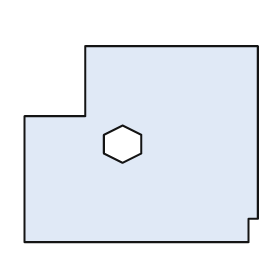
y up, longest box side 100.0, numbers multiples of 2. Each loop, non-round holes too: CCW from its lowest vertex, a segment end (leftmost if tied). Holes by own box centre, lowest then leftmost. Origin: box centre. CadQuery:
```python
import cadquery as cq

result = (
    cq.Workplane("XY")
    .moveTo(-50.0, -42.0)
    .lineTo(46.0, -42.0)
    .lineTo(46.0, -32.0)
    .lineTo(50.0, -32.0)
    .lineTo(50.0, 42.0)
    .lineTo(-24.0, 42.0)
    .lineTo(-24.0, 12.0)
    .lineTo(-50.0, 12.0)
    .close()
    .moveTo(-8.0, -8.0)
    .lineTo(0.0, -4.0)
    .lineTo(0.0, 4.0)
    .lineTo(-8.0, 8.0)
    .lineTo(-16.0, 4.0)
    .lineTo(-16.0, -4.0)
    .close()
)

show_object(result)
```